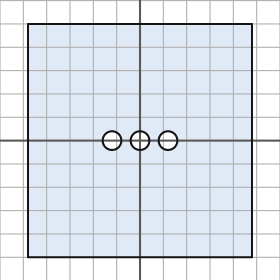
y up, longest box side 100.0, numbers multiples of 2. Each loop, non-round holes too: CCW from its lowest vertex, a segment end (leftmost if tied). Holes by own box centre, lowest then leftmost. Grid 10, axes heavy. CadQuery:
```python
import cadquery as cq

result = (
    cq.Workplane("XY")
    .moveTo(-48.0, -50.0)
    .lineTo(48.0, -50.0)
    .lineTo(48.0, 50.0)
    .lineTo(-48.0, 50.0)
    .close()
    .moveTo(-12.0, 0.0)
    .circle(4.0)
    .moveTo(0.0, 0.0)
    .circle(4.0)
    .moveTo(12.0, 0.0)
    .circle(4.0)
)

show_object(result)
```